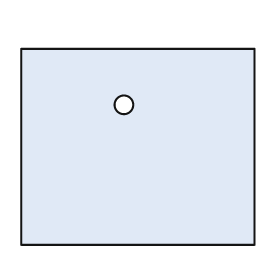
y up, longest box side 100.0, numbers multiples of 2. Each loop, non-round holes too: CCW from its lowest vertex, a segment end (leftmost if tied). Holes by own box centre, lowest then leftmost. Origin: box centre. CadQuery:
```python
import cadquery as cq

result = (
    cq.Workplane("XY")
    .moveTo(-50.0, -42.0)
    .lineTo(50.0, -42.0)
    .lineTo(50.0, 42.0)
    .lineTo(-50.0, 42.0)
    .close()
    .moveTo(-6.0, 18.0)
    .circle(4.0)
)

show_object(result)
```